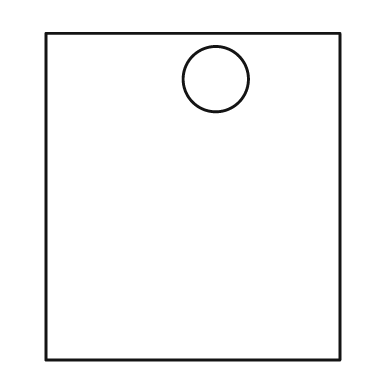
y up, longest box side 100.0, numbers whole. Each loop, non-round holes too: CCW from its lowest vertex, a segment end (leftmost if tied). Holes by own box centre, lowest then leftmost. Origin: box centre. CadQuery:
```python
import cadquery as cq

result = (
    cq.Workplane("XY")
    .moveTo(-45.0, -50.0)
    .lineTo(45.0, -50.0)
    .lineTo(45.0, 50.0)
    .lineTo(-45.0, 50.0)
    .close()
    .moveTo(7.0, 36.0)
    .circle(10.0)
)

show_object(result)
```